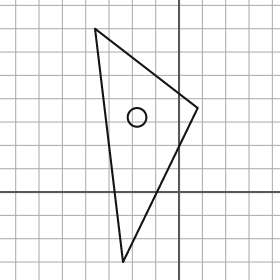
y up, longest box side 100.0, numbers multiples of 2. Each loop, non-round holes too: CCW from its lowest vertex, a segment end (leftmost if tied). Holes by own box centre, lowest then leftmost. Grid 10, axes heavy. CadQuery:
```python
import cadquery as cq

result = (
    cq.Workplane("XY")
    .moveTo(-24.0, -30.0)
    .lineTo(8.0, 36.0)
    .lineTo(-36.0, 70.0)
    .close()
    .moveTo(-18.0, 32.0)
    .circle(4.0)
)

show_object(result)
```